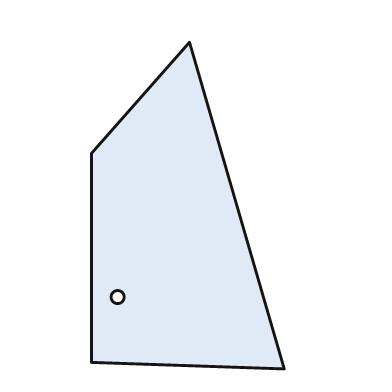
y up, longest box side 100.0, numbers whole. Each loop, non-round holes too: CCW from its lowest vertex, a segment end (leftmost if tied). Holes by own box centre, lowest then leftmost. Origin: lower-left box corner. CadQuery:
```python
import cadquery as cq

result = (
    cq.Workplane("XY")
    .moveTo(59.0, 0.0)
    .lineTo(30.0, 100.0)
    .lineTo(0.0, 66.0)
    .lineTo(0.0, 2.0)
    .close()
    .moveTo(8.0, 22.0)
    .circle(2.0)
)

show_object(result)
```